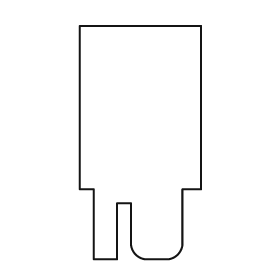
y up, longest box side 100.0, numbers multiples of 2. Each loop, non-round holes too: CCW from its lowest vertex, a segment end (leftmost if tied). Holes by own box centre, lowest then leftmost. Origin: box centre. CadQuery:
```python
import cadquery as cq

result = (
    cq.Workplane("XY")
    .moveTo(-20.0, -50.0)
    .lineTo(-10.0, -50.0)
    .lineTo(-10.0, -26.0)
    .lineTo(-4.0, -26.0)
    .lineTo(-4.0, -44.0)
    .threePointArc((-2.0, -48.0), (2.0, -50.0))
    .lineTo(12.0, -50.0)
    .threePointArc((16.0, -48.0), (18.0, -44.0))
    .lineTo(18.0, -20.0)
    .lineTo(26.0, -20.0)
    .lineTo(26.0, 50.0)
    .lineTo(-26.0, 50.0)
    .lineTo(-26.0, -20.0)
    .lineTo(-20.0, -20.0)
    .close()
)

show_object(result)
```